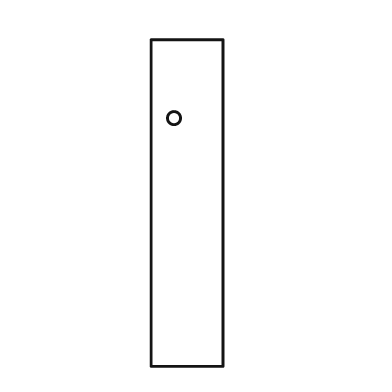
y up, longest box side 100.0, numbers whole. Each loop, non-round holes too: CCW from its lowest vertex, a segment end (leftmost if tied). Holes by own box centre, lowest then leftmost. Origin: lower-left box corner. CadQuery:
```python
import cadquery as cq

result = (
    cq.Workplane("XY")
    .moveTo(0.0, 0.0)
    .lineTo(22.0, 0.0)
    .lineTo(22.0, 100.0)
    .lineTo(0.0, 100.0)
    .close()
    .moveTo(7.0, 76.0)
    .circle(2.0)
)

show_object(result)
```